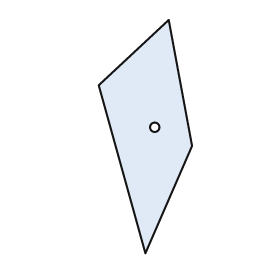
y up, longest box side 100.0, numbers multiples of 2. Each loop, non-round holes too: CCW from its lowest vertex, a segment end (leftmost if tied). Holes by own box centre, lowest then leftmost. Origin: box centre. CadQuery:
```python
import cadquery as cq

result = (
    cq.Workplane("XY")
    .moveTo(0.0, -50.0)
    .lineTo(20.0, -4.0)
    .lineTo(10.0, 50.0)
    .lineTo(-20.0, 22.0)
    .close()
    .moveTo(4.0, 4.0)
    .circle(2.0)
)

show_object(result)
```